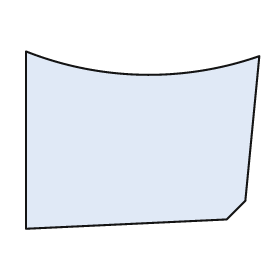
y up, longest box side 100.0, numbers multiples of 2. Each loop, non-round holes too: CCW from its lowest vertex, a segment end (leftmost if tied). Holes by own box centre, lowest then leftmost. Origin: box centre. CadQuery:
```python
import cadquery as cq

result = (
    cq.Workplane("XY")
    .moveTo(-50.0, -38.0)
    .lineTo(36.0, -34.0)
    .lineTo(44.0, -26.0)
    .lineTo(50.0, 36.0)
    .threePointArc((0.0, 28.0), (-50.0, 38.0))
    .close()
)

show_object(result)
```